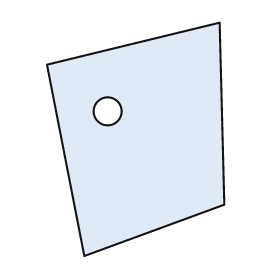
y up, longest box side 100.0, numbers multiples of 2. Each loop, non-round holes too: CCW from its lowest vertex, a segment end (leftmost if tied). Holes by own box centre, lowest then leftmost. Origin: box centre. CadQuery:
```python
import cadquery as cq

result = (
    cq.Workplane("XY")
    .moveTo(-22.0, -50.0)
    .lineTo(38.0, -28.0)
    .lineTo(36.0, 50.0)
    .lineTo(-38.0, 32.0)
    .close()
    .moveTo(-12.0, 12.0)
    .circle(6.0)
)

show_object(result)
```